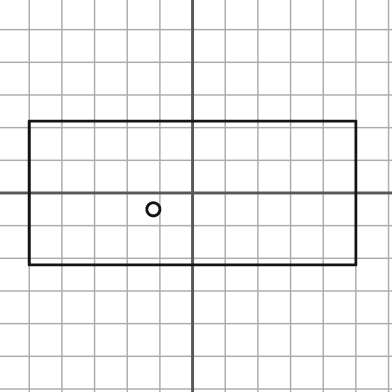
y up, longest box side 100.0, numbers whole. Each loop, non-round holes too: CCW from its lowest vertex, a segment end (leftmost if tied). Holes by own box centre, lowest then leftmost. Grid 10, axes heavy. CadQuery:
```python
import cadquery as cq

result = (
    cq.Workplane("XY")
    .moveTo(-50.0, -22.0)
    .lineTo(50.0, -22.0)
    .lineTo(50.0, 22.0)
    .lineTo(-50.0, 22.0)
    .close()
    .moveTo(-12.0, -5.0)
    .circle(2.0)
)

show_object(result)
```